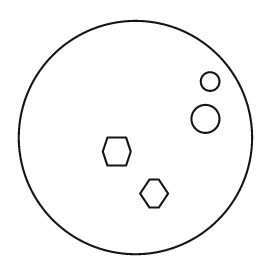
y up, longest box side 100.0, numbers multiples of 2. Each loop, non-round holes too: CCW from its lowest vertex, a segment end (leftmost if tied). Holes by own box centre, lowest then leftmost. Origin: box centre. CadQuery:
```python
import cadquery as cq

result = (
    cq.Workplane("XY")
    .moveTo(0.0, 0.0)
    .circle(50.0)
    .moveTo(6.0, -30.0)
    .lineTo(10.0, -30.0)
    .lineTo(14.0, -24.0)
    .lineTo(10.0, -18.0)
    .lineTo(6.0, -18.0)
    .lineTo(2.0, -24.0)
    .close()
    .moveTo(-12.0, -12.0)
    .lineTo(-4.0, -12.0)
    .lineTo(-2.0, -6.0)
    .lineTo(-4.0, 0.0)
    .lineTo(-12.0, 0.0)
    .lineTo(-14.0, -6.0)
    .close()
    .moveTo(30.0, 8.0)
    .circle(6.0)
    .moveTo(32.0, 24.0)
    .circle(4.0)
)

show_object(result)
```